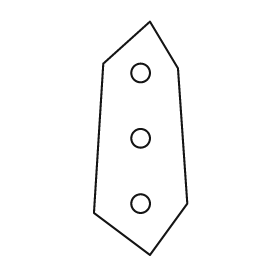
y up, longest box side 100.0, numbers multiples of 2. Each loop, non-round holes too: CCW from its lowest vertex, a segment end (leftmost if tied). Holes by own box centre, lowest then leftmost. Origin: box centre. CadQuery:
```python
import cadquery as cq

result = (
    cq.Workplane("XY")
    .moveTo(4.0, -50.0)
    .lineTo(20.0, -28.0)
    .lineTo(16.0, 30.0)
    .lineTo(4.0, 50.0)
    .lineTo(-16.0, 32.0)
    .lineTo(-20.0, -32.0)
    .close()
    .moveTo(0.0, -28.0)
    .circle(4.0)
    .moveTo(0.0, 0.0)
    .circle(4.0)
    .moveTo(0.0, 28.0)
    .circle(4.0)
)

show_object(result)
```